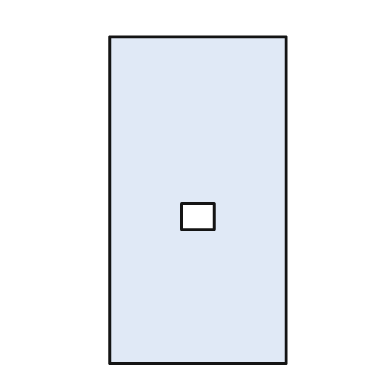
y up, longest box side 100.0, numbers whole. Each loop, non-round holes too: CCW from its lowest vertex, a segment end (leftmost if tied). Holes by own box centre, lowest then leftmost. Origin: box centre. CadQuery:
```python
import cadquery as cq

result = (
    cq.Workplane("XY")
    .moveTo(-27.0, -50.0)
    .lineTo(27.0, -50.0)
    .lineTo(27.0, 50.0)
    .lineTo(-27.0, 50.0)
    .close()
    .moveTo(-5.0, -9.0)
    .lineTo(5.0, -9.0)
    .lineTo(5.0, -1.0)
    .lineTo(-5.0, -1.0)
    .close()
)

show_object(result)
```